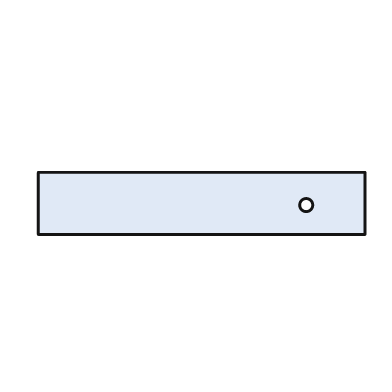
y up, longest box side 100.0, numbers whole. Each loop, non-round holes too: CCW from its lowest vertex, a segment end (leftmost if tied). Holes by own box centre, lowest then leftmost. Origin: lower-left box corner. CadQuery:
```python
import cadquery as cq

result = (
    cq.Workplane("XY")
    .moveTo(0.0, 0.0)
    .lineTo(100.0, 0.0)
    .lineTo(100.0, 19.0)
    .lineTo(0.0, 19.0)
    .close()
    .moveTo(82.0, 9.0)
    .circle(2.0)
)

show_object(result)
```